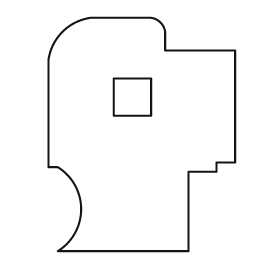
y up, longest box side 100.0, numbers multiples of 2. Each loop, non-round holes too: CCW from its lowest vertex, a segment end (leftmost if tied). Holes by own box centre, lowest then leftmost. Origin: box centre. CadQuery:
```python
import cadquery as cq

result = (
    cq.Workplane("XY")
    .moveTo(-36.0, -50.0)
    .lineTo(20.0, -50.0)
    .lineTo(20.0, -16.0)
    .lineTo(32.0, -16.0)
    .lineTo(32.0, -12.0)
    .lineTo(40.0, -12.0)
    .lineTo(40.0, 36.0)
    .lineTo(10.0, 36.0)
    .lineTo(10.0, 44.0)
    .threePointArc((8.0, 48.0), (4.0, 50.0))
    .lineTo(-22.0, 50.0)
    .threePointArc((-34.0, 44.0), (-40.0, 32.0))
    .lineTo(-40.0, -14.0)
    .lineTo(-36.0, -14.0)
    .threePointArc((-26.0, -32.0), (-36.0, -50.0))
    .close()
    .moveTo(-12.0, 8.0)
    .lineTo(4.0, 8.0)
    .lineTo(4.0, 24.0)
    .lineTo(-12.0, 24.0)
    .close()
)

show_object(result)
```